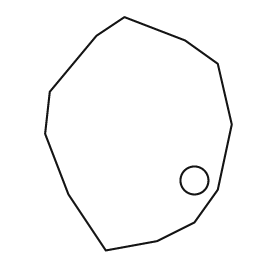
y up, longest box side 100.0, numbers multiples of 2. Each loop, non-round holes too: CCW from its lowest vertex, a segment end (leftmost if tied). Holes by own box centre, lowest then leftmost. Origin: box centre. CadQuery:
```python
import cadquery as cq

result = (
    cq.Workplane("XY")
    .moveTo(-14.0, -50.0)
    .lineTo(8.0, -46.0)
    .lineTo(24.0, -38.0)
    .lineTo(34.0, -24.0)
    .lineTo(40.0, 4.0)
    .lineTo(34.0, 30.0)
    .lineTo(20.0, 40.0)
    .lineTo(-6.0, 50.0)
    .lineTo(-18.0, 42.0)
    .lineTo(-38.0, 18.0)
    .lineTo(-40.0, 0.0)
    .lineTo(-30.0, -26.0)
    .close()
    .moveTo(24.0, -20.0)
    .circle(6.0)
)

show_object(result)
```